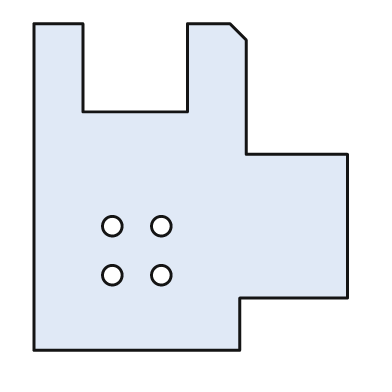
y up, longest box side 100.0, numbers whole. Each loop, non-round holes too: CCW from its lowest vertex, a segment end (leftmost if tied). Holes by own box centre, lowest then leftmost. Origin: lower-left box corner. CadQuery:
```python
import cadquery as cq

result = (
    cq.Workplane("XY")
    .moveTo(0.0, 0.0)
    .lineTo(63.0, 0.0)
    .lineTo(63.0, 16.0)
    .lineTo(96.0, 16.0)
    .lineTo(96.0, 60.0)
    .lineTo(65.0, 60.0)
    .lineTo(65.0, 95.0)
    .lineTo(60.0, 100.0)
    .lineTo(47.0, 100.0)
    .lineTo(47.0, 73.0)
    .lineTo(15.0, 73.0)
    .lineTo(15.0, 100.0)
    .lineTo(0.0, 100.0)
    .close()
    .moveTo(24.0, 23.0)
    .circle(3.0)
    .moveTo(39.0, 23.0)
    .circle(3.0)
    .moveTo(24.0, 38.0)
    .circle(3.0)
    .moveTo(39.0, 38.0)
    .circle(3.0)
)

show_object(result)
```